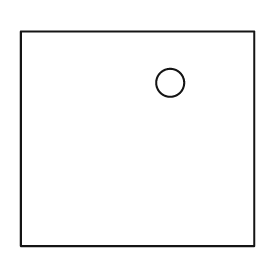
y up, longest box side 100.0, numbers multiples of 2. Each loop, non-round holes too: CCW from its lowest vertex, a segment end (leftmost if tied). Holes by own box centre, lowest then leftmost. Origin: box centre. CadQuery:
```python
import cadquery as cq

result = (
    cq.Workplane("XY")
    .moveTo(-50.0, -46.0)
    .lineTo(50.0, -46.0)
    .lineTo(50.0, 46.0)
    .lineTo(-50.0, 46.0)
    .close()
    .moveTo(14.0, 24.0)
    .circle(6.0)
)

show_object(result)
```